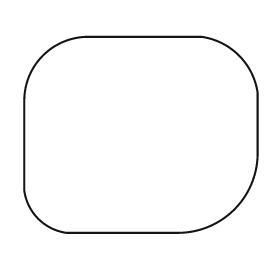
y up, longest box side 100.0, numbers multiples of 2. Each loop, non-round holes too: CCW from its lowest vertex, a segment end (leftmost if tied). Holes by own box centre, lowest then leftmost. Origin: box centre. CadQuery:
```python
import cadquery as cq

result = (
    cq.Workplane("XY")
    .moveTo(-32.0, -42.0)
    .lineTo(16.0, -42.0)
    .threePointArc((40.0, -32.0), (50.0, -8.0))
    .lineTo(50.0, 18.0)
    .threePointArc((42.0, 34.0), (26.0, 42.0))
    .lineTo(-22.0, 42.0)
    .threePointArc((-42.0, 34.0), (-50.0, 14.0))
    .lineTo(-50.0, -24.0)
    .threePointArc((-44.0, -36.0), (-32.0, -42.0))
    .close()
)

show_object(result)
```